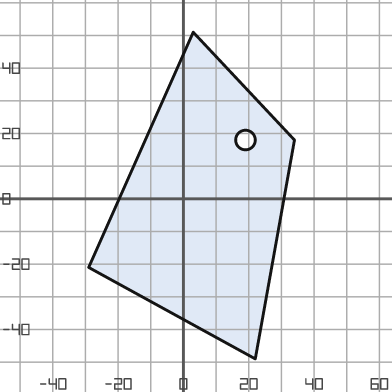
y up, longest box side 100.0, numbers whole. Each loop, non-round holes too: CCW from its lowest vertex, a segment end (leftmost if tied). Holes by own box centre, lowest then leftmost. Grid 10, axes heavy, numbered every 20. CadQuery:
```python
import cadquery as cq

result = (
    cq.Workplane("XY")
    .moveTo(22.0, -49.0)
    .lineTo(34.0, 18.0)
    .lineTo(3.0, 51.0)
    .lineTo(-29.0, -21.0)
    .close()
    .moveTo(19.0, 18.0)
    .circle(3.0)
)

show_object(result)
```